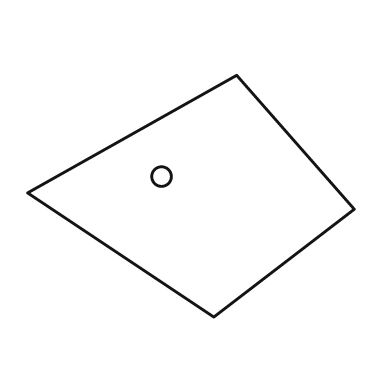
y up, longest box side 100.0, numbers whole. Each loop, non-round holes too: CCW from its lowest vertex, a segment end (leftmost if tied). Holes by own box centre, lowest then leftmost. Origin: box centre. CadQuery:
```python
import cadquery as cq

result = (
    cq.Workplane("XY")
    .moveTo(7.0, -37.0)
    .lineTo(50.0, -4.0)
    .lineTo(14.0, 37.0)
    .lineTo(-50.0, 1.0)
    .close()
    .moveTo(-9.0, 6.0)
    .circle(3.0)
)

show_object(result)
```